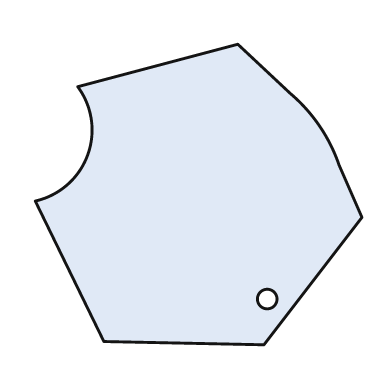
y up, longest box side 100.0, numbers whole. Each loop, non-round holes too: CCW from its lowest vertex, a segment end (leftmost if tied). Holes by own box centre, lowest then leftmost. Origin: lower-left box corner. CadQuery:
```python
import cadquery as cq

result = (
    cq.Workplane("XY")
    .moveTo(70.0, 0.0)
    .lineTo(100.0, 39.0)
    .lineTo(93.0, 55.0)
    .threePointArc((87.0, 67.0), (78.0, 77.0))
    .lineTo(62.0, 92.0)
    .lineTo(13.0, 79.0)
    .threePointArc((16.0, 58.0), (0.0, 44.0))
    .lineTo(21.0, 1.0)
    .close()
    .moveTo(71.0, 14.0)
    .circle(3.0)
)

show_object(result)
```